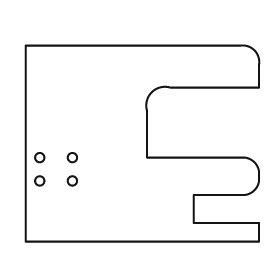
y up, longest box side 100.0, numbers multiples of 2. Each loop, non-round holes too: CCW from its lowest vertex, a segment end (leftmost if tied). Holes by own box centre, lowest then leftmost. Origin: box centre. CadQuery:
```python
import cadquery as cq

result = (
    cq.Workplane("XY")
    .moveTo(-50.0, -42.0)
    .lineTo(50.0, -42.0)
    .lineTo(50.0, -34.0)
    .lineTo(22.0, -34.0)
    .lineTo(22.0, -22.0)
    .lineTo(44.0, -22.0)
    .threePointArc((48.0, -20.0), (50.0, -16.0))
    .lineTo(50.0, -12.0)
    .threePointArc((48.0, -8.0), (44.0, -6.0))
    .lineTo(2.0, -6.0)
    .lineTo(2.0, 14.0)
    .threePointArc((4.0, 22.0), (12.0, 24.0))
    .lineTo(50.0, 24.0)
    .lineTo(50.0, 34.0)
    .threePointArc((48.0, 40.0), (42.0, 42.0))
    .lineTo(-50.0, 42.0)
    .close()
    .moveTo(-44.0, -16.0)
    .circle(2.0)
    .moveTo(-30.0, -16.0)
    .circle(2.0)
    .moveTo(-44.0, -6.0)
    .circle(2.0)
    .moveTo(-30.0, -6.0)
    .circle(2.0)
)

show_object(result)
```